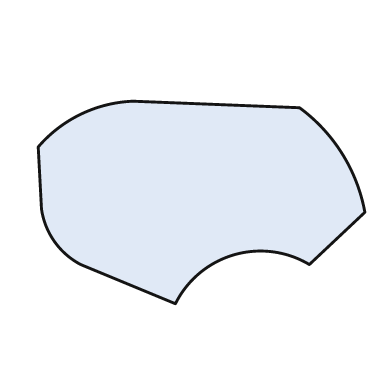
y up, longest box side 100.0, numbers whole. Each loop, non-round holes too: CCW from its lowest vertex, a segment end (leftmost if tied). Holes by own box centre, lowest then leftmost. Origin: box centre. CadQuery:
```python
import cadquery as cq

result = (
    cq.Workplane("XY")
    .moveTo(-8.0, -31.0)
    .threePointArc((10.0, -16.0), (33.0, -19.0))
    .lineTo(50.0, -3.0)
    .threePointArc((43.0, 15.0), (30.0, 29.0))
    .lineTo(-21.0, 31.0)
    .threePointArc((-37.0, 27.0), (-50.0, 17.0))
    .lineTo(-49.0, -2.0)
    .threePointArc((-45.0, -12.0), (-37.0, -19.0))
    .close()
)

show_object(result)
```